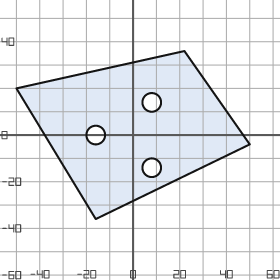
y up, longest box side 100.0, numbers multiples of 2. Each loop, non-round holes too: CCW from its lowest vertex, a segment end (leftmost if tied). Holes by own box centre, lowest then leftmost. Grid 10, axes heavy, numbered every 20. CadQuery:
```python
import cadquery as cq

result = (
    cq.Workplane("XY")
    .moveTo(-16.0, -36.0)
    .lineTo(50.0, -4.0)
    .lineTo(22.0, 36.0)
    .lineTo(-50.0, 20.0)
    .close()
    .moveTo(8.0, -14.0)
    .circle(4.0)
    .moveTo(-16.0, 0.0)
    .circle(4.0)
    .moveTo(8.0, 14.0)
    .circle(4.0)
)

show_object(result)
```